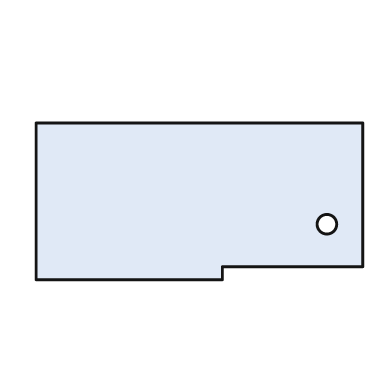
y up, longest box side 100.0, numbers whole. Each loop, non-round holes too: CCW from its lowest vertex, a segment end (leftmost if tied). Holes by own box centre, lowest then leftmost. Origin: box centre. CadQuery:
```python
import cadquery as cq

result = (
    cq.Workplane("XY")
    .moveTo(-50.0, -24.0)
    .lineTo(7.0, -24.0)
    .lineTo(7.0, -20.0)
    .lineTo(50.0, -20.0)
    .lineTo(50.0, 24.0)
    .lineTo(-50.0, 24.0)
    .close()
    .moveTo(39.0, -7.0)
    .circle(3.0)
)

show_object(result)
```